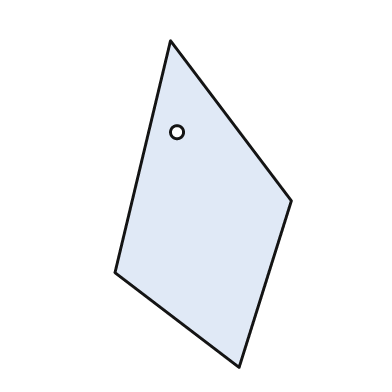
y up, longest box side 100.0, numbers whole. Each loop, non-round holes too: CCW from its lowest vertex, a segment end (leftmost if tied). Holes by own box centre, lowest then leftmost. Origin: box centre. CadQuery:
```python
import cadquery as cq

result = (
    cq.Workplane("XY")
    .moveTo(11.0, -50.0)
    .lineTo(27.0, 1.0)
    .lineTo(-10.0, 50.0)
    .lineTo(-27.0, -21.0)
    .close()
    .moveTo(-8.0, 22.0)
    .circle(2.0)
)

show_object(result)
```